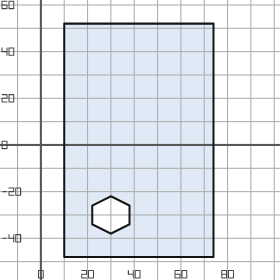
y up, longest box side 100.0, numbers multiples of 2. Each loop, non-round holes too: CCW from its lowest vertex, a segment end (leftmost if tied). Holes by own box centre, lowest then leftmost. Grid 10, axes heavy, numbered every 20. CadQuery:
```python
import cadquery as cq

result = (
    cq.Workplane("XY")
    .moveTo(10.0, -48.0)
    .lineTo(74.0, -48.0)
    .lineTo(74.0, 52.0)
    .lineTo(10.0, 52.0)
    .close()
    .moveTo(30.0, -38.0)
    .lineTo(38.0, -34.0)
    .lineTo(38.0, -26.0)
    .lineTo(30.0, -22.0)
    .lineTo(22.0, -26.0)
    .lineTo(22.0, -34.0)
    .close()
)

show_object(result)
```